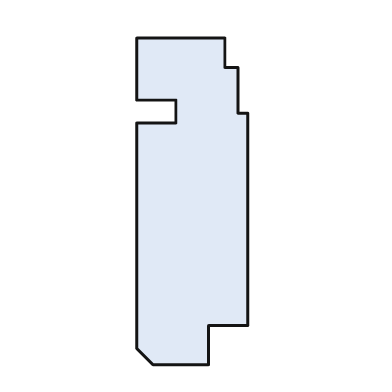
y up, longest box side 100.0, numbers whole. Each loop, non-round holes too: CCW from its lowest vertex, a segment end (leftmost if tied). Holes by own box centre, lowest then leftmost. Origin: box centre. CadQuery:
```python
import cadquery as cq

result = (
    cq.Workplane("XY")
    .moveTo(-12.0, -50.0)
    .lineTo(5.0, -50.0)
    .lineTo(5.0, -38.0)
    .lineTo(17.0, -38.0)
    .lineTo(17.0, 27.0)
    .lineTo(14.0, 27.0)
    .lineTo(14.0, 41.0)
    .lineTo(10.0, 41.0)
    .lineTo(10.0, 50.0)
    .lineTo(-17.0, 50.0)
    .lineTo(-17.0, 31.0)
    .lineTo(-5.0, 31.0)
    .lineTo(-5.0, 24.0)
    .lineTo(-17.0, 24.0)
    .lineTo(-17.0, -45.0)
    .close()
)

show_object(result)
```